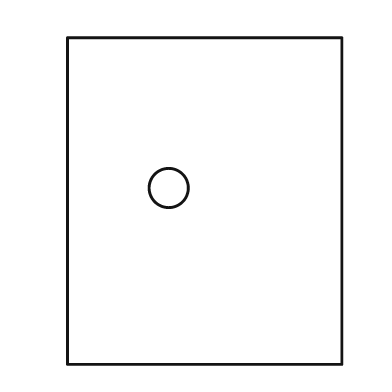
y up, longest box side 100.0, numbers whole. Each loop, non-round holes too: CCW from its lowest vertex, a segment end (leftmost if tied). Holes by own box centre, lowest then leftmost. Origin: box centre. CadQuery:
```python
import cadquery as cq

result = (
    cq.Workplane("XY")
    .moveTo(-42.0, -50.0)
    .lineTo(42.0, -50.0)
    .lineTo(42.0, 50.0)
    .lineTo(-42.0, 50.0)
    .close()
    .moveTo(-11.0, 4.0)
    .circle(6.0)
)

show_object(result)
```